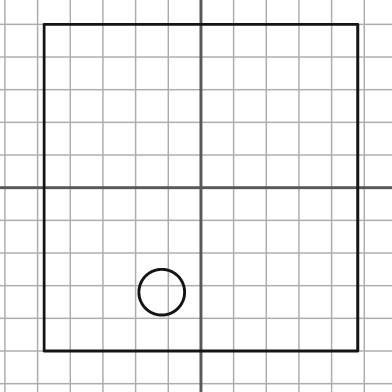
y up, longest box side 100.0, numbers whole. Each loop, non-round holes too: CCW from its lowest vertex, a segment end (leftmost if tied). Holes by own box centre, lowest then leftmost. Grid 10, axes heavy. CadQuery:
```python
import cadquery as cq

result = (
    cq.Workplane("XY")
    .moveTo(-48.0, -50.0)
    .lineTo(48.0, -50.0)
    .lineTo(48.0, 50.0)
    .lineTo(-48.0, 50.0)
    .close()
    .moveTo(-12.0, -32.0)
    .circle(7.0)
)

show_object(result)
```